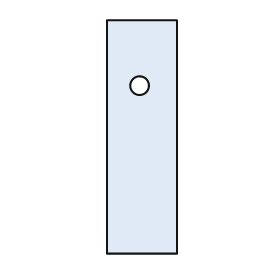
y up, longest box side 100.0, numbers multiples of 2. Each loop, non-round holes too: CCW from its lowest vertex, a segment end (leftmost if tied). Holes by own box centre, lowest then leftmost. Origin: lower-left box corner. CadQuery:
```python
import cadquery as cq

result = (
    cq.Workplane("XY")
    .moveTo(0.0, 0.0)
    .lineTo(30.0, 0.0)
    .lineTo(30.0, 100.0)
    .lineTo(0.0, 100.0)
    .close()
    .moveTo(14.0, 72.0)
    .circle(4.0)
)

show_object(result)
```